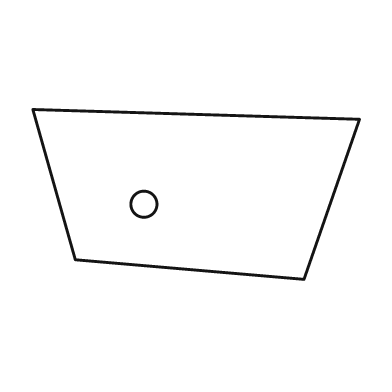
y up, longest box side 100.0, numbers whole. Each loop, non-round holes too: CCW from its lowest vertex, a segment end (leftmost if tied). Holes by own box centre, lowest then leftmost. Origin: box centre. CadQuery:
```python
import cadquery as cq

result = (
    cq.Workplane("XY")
    .moveTo(33.0, -26.0)
    .lineTo(50.0, 23.0)
    .lineTo(-50.0, 26.0)
    .lineTo(-37.0, -20.0)
    .close()
    .moveTo(-16.0, -3.0)
    .circle(4.0)
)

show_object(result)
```